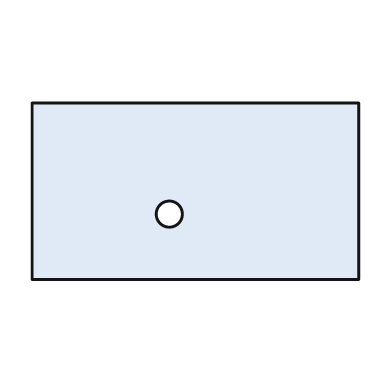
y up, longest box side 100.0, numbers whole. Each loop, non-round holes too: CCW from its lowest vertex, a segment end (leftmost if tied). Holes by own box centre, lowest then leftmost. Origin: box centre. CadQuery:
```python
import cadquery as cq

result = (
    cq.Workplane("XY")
    .moveTo(-50.0, -27.0)
    .lineTo(50.0, -27.0)
    .lineTo(50.0, 27.0)
    .lineTo(-50.0, 27.0)
    .close()
    .moveTo(-8.0, -7.0)
    .circle(4.0)
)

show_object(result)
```